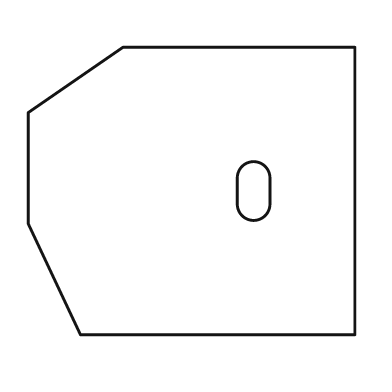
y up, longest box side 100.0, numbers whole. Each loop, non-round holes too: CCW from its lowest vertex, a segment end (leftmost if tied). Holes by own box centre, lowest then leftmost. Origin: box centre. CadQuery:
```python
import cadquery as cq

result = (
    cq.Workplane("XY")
    .moveTo(-34.0, -44.0)
    .lineTo(50.0, -44.0)
    .lineTo(50.0, 44.0)
    .lineTo(-21.0, 44.0)
    .lineTo(-50.0, 24.0)
    .lineTo(-50.0, -10.0)
    .close()
    .moveTo(14.0, -4.0)
    .threePointArc((19.0, -9.0), (24.0, -4.0))
    .lineTo(24.0, 4.0)
    .threePointArc((19.0, 9.0), (14.0, 4.0))
    .close()
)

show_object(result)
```